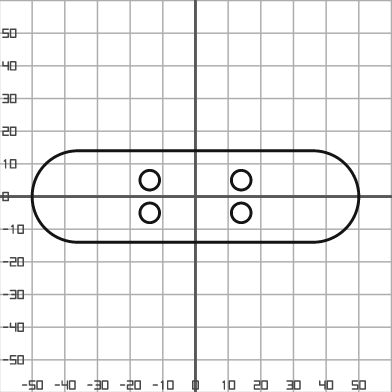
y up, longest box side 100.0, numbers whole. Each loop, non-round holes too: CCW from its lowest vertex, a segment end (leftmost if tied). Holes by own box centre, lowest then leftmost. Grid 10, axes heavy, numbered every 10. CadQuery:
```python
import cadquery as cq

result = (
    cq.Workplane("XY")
    .moveTo(-36.0, -14.0)
    .lineTo(36.0, -14.0)
    .threePointArc((50.0, 0.0), (36.0, 14.0))
    .lineTo(-36.0, 14.0)
    .threePointArc((-50.0, 0.0), (-36.0, -14.0))
    .close()
    .moveTo(-14.0, -5.0)
    .circle(3.0)
    .moveTo(14.0, -5.0)
    .circle(3.0)
    .moveTo(-14.0, 5.0)
    .circle(3.0)
    .moveTo(14.0, 5.0)
    .circle(3.0)
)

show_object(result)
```